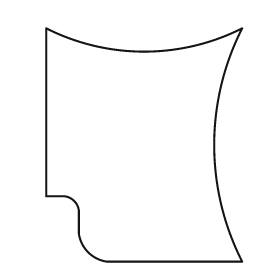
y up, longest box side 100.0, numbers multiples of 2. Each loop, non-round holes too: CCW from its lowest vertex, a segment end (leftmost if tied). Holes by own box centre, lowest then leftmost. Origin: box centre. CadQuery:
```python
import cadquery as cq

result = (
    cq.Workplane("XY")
    .moveTo(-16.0, -50.0)
    .lineTo(42.0, -50.0)
    .threePointArc((30.0, 0.0), (42.0, 50.0))
    .threePointArc((0.0, 40.0), (-42.0, 50.0))
    .lineTo(-42.0, -22.0)
    .lineTo(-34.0, -22.0)
    .threePointArc((-30.0, -24.0), (-28.0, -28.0))
    .lineTo(-28.0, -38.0)
    .threePointArc((-24.0, -46.0), (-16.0, -50.0))
    .close()
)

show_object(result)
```